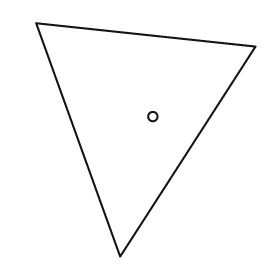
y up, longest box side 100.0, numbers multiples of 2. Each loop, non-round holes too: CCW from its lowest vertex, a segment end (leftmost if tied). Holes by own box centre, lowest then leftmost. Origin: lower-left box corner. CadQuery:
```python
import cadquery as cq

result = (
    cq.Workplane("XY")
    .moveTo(36.0, 0.0)
    .lineTo(94.0, 90.0)
    .lineTo(0.0, 100.0)
    .close()
    .moveTo(50.0, 60.0)
    .circle(2.0)
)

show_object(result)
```